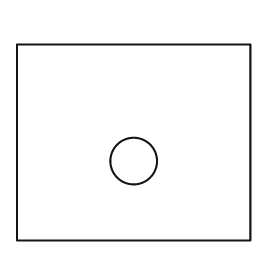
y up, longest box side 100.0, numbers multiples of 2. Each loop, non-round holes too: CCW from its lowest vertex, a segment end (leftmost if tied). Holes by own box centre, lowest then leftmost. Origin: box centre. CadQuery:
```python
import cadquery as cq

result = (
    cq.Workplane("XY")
    .moveTo(-50.0, -42.0)
    .lineTo(50.0, -42.0)
    .lineTo(50.0, 42.0)
    .lineTo(-50.0, 42.0)
    .close()
    .moveTo(0.0, -8.0)
    .circle(10.0)
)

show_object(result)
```